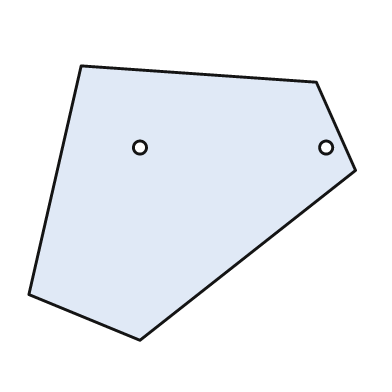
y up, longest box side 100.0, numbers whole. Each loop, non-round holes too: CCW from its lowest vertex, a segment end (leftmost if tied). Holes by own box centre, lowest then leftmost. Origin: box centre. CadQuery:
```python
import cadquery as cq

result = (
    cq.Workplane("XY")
    .moveTo(-16.0, -42.0)
    .lineTo(50.0, 10.0)
    .lineTo(38.0, 37.0)
    .lineTo(-34.0, 42.0)
    .lineTo(-50.0, -28.0)
    .close()
    .moveTo(-16.0, 17.0)
    .circle(2.0)
    .moveTo(41.0, 17.0)
    .circle(2.0)
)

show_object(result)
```